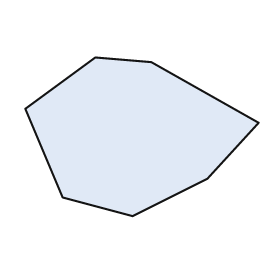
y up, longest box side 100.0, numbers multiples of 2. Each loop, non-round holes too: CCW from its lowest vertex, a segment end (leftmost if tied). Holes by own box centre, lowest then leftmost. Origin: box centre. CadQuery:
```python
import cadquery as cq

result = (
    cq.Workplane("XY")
    .moveTo(-4.0, -34.0)
    .lineTo(28.0, -18.0)
    .lineTo(50.0, 6.0)
    .lineTo(4.0, 32.0)
    .lineTo(-20.0, 34.0)
    .lineTo(-50.0, 12.0)
    .lineTo(-34.0, -26.0)
    .close()
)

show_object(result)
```